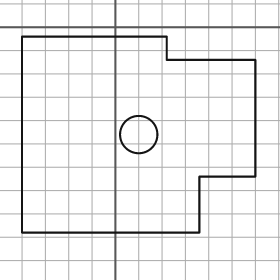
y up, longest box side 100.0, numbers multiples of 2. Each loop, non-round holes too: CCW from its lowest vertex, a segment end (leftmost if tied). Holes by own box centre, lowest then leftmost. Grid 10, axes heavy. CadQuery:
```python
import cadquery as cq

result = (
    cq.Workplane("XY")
    .moveTo(-40.0, -88.0)
    .lineTo(36.0, -88.0)
    .lineTo(36.0, -64.0)
    .lineTo(60.0, -64.0)
    .lineTo(60.0, -14.0)
    .lineTo(22.0, -14.0)
    .lineTo(22.0, -4.0)
    .lineTo(-40.0, -4.0)
    .close()
    .moveTo(10.0, -46.0)
    .circle(8.0)
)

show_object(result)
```